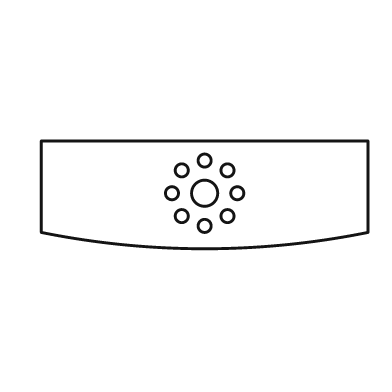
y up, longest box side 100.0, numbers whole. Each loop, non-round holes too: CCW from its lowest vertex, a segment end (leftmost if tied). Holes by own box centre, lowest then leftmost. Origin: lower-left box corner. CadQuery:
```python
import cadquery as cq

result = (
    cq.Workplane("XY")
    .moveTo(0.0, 5.0)
    .threePointArc((50.0, 0.0), (100.0, 5.0))
    .lineTo(100.0, 33.0)
    .lineTo(0.0, 33.0)
    .close()
    .moveTo(50.0, 7.0)
    .circle(2.0)
    .moveTo(43.0, 10.0)
    .circle(2.0)
    .moveTo(57.0, 10.0)
    .circle(2.0)
    .moveTo(40.0, 17.0)
    .circle(2.0)
    .moveTo(50.0, 17.0)
    .circle(4.0)
    .moveTo(60.0, 17.0)
    .circle(2.0)
    .moveTo(43.0, 24.0)
    .circle(2.0)
    .moveTo(57.0, 24.0)
    .circle(2.0)
    .moveTo(50.0, 27.0)
    .circle(2.0)
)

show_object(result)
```